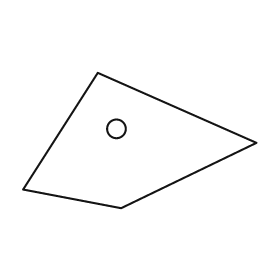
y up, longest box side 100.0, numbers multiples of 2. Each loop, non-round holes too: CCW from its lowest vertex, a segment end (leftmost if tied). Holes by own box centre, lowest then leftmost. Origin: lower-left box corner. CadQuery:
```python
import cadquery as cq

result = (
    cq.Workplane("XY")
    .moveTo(42.0, 0.0)
    .lineTo(100.0, 28.0)
    .lineTo(32.0, 58.0)
    .lineTo(0.0, 8.0)
    .close()
    .moveTo(40.0, 34.0)
    .circle(4.0)
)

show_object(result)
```